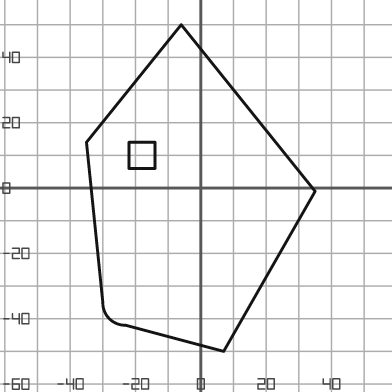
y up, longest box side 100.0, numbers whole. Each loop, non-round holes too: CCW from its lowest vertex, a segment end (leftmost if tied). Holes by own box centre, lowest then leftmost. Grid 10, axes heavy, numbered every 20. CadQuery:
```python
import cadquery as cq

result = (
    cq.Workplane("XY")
    .moveTo(7.0, -50.0)
    .lineTo(35.0, -1.0)
    .lineTo(-6.0, 50.0)
    .lineTo(-35.0, 14.0)
    .lineTo(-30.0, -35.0)
    .threePointArc((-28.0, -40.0), (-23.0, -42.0))
    .close()
    .moveTo(-22.0, 6.0)
    .lineTo(-14.0, 6.0)
    .lineTo(-14.0, 14.0)
    .lineTo(-22.0, 14.0)
    .close()
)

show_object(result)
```